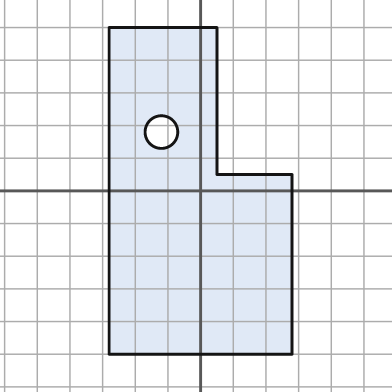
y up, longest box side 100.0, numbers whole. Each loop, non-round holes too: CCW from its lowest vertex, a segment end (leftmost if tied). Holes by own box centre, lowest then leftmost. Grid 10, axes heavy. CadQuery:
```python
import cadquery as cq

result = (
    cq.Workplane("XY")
    .moveTo(-28.0, -50.0)
    .lineTo(28.0, -50.0)
    .lineTo(28.0, 5.0)
    .lineTo(5.0, 5.0)
    .lineTo(5.0, 50.0)
    .lineTo(-28.0, 50.0)
    .close()
    .moveTo(-12.0, 18.0)
    .circle(5.0)
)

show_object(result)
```